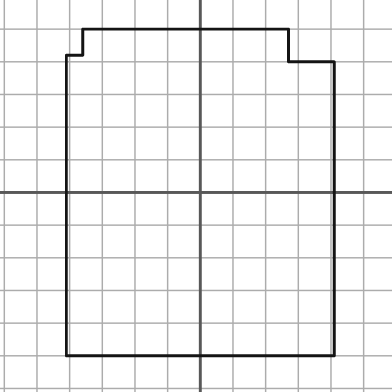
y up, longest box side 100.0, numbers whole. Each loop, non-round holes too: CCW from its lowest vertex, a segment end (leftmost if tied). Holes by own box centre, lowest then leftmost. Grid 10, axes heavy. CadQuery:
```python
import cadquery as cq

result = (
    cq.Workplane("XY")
    .moveTo(-41.0, -50.0)
    .lineTo(41.0, -50.0)
    .lineTo(41.0, 40.0)
    .lineTo(27.0, 40.0)
    .lineTo(27.0, 50.0)
    .lineTo(-36.0, 50.0)
    .lineTo(-36.0, 42.0)
    .lineTo(-41.0, 42.0)
    .close()
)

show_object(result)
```